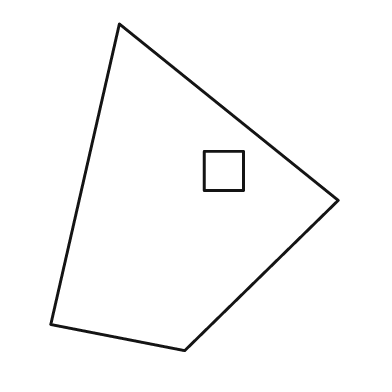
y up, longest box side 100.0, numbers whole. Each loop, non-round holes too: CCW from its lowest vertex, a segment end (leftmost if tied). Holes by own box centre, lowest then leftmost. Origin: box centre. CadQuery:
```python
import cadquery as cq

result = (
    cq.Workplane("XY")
    .moveTo(-3.0, -50.0)
    .lineTo(44.0, -4.0)
    .lineTo(-23.0, 50.0)
    .lineTo(-44.0, -42.0)
    .close()
    .moveTo(3.0, -1.0)
    .lineTo(15.0, -1.0)
    .lineTo(15.0, 11.0)
    .lineTo(3.0, 11.0)
    .close()
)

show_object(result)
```